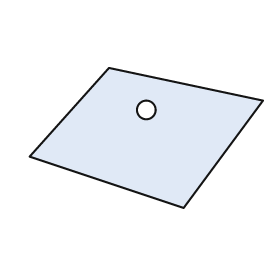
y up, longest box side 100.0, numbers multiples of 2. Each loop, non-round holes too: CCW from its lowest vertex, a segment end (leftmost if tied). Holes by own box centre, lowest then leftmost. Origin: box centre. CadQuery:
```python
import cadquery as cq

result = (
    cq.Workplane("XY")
    .moveTo(16.0, -30.0)
    .lineTo(50.0, 16.0)
    .lineTo(-16.0, 30.0)
    .lineTo(-50.0, -8.0)
    .close()
    .moveTo(0.0, 12.0)
    .circle(4.0)
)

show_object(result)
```